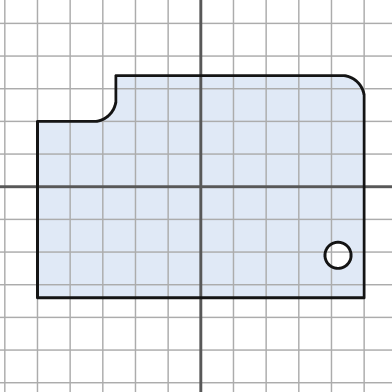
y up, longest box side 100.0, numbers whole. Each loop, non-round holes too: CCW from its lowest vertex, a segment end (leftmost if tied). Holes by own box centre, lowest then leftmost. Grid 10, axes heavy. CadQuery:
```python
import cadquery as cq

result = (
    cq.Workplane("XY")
    .moveTo(-50.0, -34.0)
    .lineTo(50.0, -34.0)
    .lineTo(50.0, 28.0)
    .threePointArc((48.0, 32.0), (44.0, 34.0))
    .lineTo(-26.0, 34.0)
    .lineTo(-26.0, 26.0)
    .threePointArc((-28.0, 22.0), (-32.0, 20.0))
    .lineTo(-50.0, 20.0)
    .close()
    .moveTo(42.0, -21.0)
    .circle(4.0)
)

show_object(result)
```